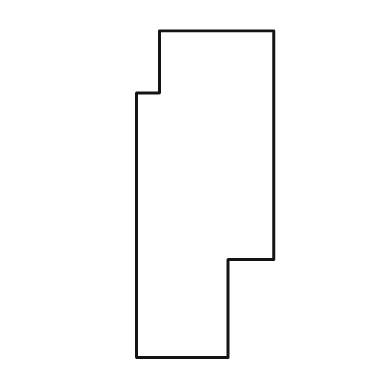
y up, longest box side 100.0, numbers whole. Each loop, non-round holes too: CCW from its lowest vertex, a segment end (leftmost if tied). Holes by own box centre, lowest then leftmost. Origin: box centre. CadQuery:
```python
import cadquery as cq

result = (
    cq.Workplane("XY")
    .moveTo(-21.0, -50.0)
    .lineTo(7.0, -50.0)
    .lineTo(7.0, -20.0)
    .lineTo(21.0, -20.0)
    .lineTo(21.0, 50.0)
    .lineTo(-14.0, 50.0)
    .lineTo(-14.0, 31.0)
    .lineTo(-21.0, 31.0)
    .close()
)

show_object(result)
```